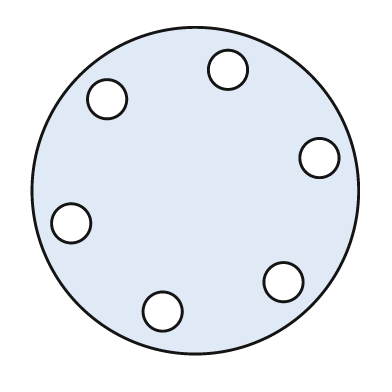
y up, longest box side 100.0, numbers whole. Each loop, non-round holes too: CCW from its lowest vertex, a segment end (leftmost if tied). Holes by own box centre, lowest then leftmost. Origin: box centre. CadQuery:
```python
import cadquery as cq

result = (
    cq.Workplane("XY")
    .moveTo(0.0, 0.0)
    .circle(50.0)
    .moveTo(-10.0, -37.0)
    .circle(6.0)
    .moveTo(27.0, -28.0)
    .circle(6.0)
    .moveTo(-38.0, -10.0)
    .circle(6.0)
    .moveTo(38.0, 10.0)
    .circle(6.0)
    .moveTo(-27.0, 28.0)
    .circle(6.0)
    .moveTo(10.0, 37.0)
    .circle(6.0)
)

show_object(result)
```